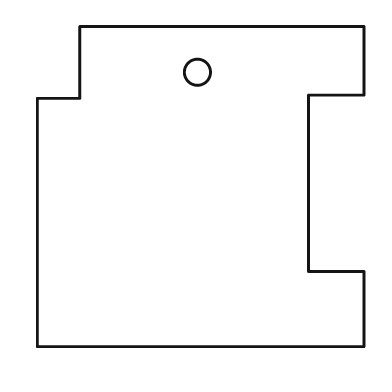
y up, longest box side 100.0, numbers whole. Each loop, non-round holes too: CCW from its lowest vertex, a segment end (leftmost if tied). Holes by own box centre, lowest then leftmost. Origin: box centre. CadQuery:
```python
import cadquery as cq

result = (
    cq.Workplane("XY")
    .moveTo(-50.0, -49.0)
    .lineTo(50.0, -49.0)
    .lineTo(50.0, -26.0)
    .lineTo(33.0, -26.0)
    .lineTo(33.0, 28.0)
    .lineTo(50.0, 28.0)
    .lineTo(50.0, 49.0)
    .lineTo(-37.0, 49.0)
    .lineTo(-37.0, 27.0)
    .lineTo(-50.0, 27.0)
    .close()
    .moveTo(-1.0, 35.0)
    .circle(4.0)
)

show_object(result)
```